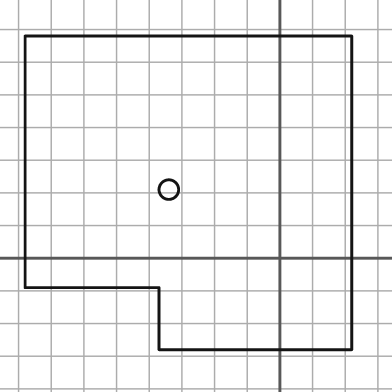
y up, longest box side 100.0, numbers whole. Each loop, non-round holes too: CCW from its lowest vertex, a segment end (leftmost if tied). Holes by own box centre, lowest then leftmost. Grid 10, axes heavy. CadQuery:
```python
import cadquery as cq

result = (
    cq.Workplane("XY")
    .moveTo(-37.0, -28.0)
    .lineTo(22.0, -28.0)
    .lineTo(22.0, 68.0)
    .lineTo(-78.0, 68.0)
    .lineTo(-78.0, -9.0)
    .lineTo(-37.0, -9.0)
    .close()
    .moveTo(-34.0, 21.0)
    .circle(3.0)
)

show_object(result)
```